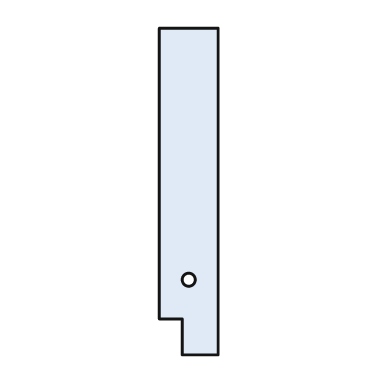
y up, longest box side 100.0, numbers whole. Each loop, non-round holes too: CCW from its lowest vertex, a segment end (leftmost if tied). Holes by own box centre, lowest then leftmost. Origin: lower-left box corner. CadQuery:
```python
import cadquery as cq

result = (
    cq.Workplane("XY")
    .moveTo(7.0, 0.0)
    .lineTo(18.0, 0.0)
    .lineTo(18.0, 100.0)
    .lineTo(0.0, 100.0)
    .lineTo(0.0, 11.0)
    .lineTo(7.0, 11.0)
    .close()
    .moveTo(9.0, 23.0)
    .circle(2.0)
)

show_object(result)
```